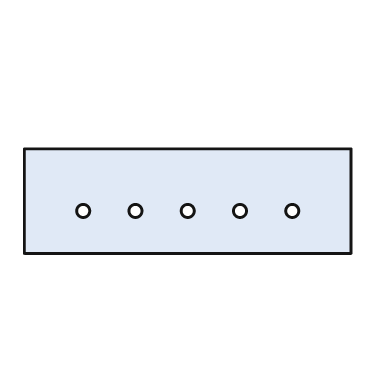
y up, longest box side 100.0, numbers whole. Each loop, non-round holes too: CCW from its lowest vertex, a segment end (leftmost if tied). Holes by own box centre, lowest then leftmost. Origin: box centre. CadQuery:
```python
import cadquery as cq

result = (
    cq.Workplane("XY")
    .moveTo(-50.0, -16.0)
    .lineTo(50.0, -16.0)
    .lineTo(50.0, 16.0)
    .lineTo(-50.0, 16.0)
    .close()
    .moveTo(-32.0, -3.0)
    .circle(2.0)
    .moveTo(-16.0, -3.0)
    .circle(2.0)
    .moveTo(0.0, -3.0)
    .circle(2.0)
    .moveTo(16.0, -3.0)
    .circle(2.0)
    .moveTo(32.0, -3.0)
    .circle(2.0)
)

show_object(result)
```